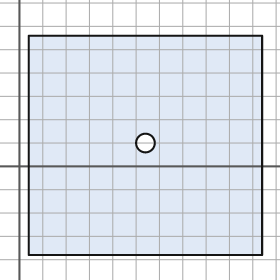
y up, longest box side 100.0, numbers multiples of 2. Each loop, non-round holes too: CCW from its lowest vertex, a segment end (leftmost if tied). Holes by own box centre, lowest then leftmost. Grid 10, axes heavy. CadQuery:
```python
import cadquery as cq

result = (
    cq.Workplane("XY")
    .moveTo(4.0, -38.0)
    .lineTo(104.0, -38.0)
    .lineTo(104.0, 56.0)
    .lineTo(4.0, 56.0)
    .close()
    .moveTo(54.0, 10.0)
    .circle(4.0)
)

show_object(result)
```